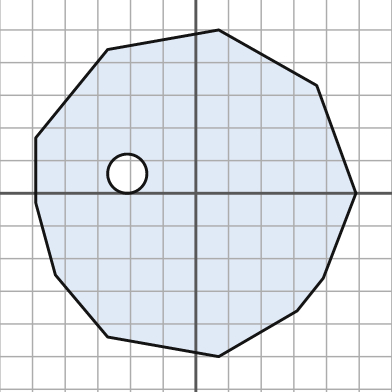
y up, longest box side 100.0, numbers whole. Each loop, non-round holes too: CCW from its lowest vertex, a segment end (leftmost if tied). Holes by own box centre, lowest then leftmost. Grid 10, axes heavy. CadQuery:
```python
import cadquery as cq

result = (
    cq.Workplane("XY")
    .moveTo(7.0, -50.0)
    .lineTo(31.0, -36.0)
    .lineTo(39.0, -26.0)
    .lineTo(49.0, 0.0)
    .lineTo(37.0, 33.0)
    .lineTo(7.0, 50.0)
    .lineTo(-27.0, 44.0)
    .lineTo(-49.0, 17.0)
    .lineTo(-49.0, -3.0)
    .lineTo(-43.0, -25.0)
    .lineTo(-27.0, -44.0)
    .close()
    .moveTo(-21.0, 6.0)
    .circle(6.0)
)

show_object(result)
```